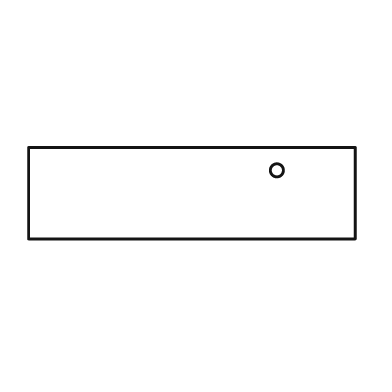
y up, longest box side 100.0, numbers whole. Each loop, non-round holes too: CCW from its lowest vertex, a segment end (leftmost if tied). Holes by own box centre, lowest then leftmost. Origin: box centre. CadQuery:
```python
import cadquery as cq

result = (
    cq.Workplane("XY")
    .moveTo(-50.0, -14.0)
    .lineTo(50.0, -14.0)
    .lineTo(50.0, 14.0)
    .lineTo(-50.0, 14.0)
    .close()
    .moveTo(26.0, 7.0)
    .circle(2.0)
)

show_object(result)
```